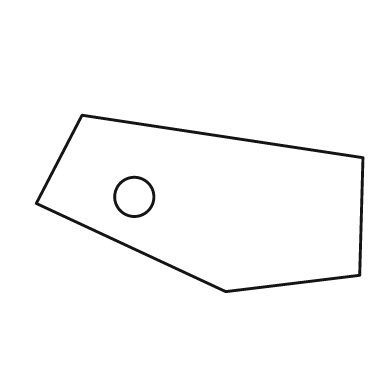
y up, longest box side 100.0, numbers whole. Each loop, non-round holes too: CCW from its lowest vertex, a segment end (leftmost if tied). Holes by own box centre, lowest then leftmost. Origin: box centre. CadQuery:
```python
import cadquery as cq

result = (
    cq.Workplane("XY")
    .moveTo(8.0, -27.0)
    .lineTo(49.0, -22.0)
    .lineTo(50.0, 14.0)
    .lineTo(-36.0, 27.0)
    .lineTo(-50.0, 0.0)
    .close()
    .moveTo(-20.0, 2.0)
    .circle(6.0)
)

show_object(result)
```